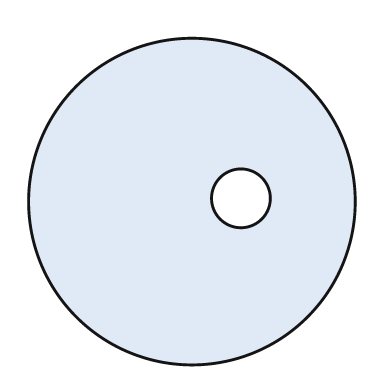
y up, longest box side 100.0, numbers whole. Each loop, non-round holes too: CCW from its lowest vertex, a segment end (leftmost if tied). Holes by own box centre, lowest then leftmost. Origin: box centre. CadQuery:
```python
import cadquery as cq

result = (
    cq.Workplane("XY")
    .moveTo(0.0, 0.0)
    .circle(50.0)
    .moveTo(15.0, 1.0)
    .circle(9.0)
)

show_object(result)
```